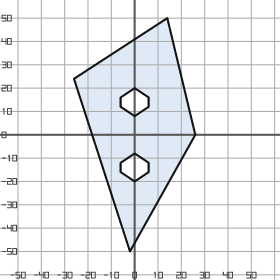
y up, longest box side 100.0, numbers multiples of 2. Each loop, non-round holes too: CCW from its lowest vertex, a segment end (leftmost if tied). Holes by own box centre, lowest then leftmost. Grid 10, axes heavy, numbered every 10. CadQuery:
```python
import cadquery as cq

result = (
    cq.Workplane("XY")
    .moveTo(-2.0, -50.0)
    .lineTo(26.0, 0.0)
    .lineTo(14.0, 50.0)
    .lineTo(-26.0, 24.0)
    .close()
    .moveTo(0.0, -20.0)
    .lineTo(6.0, -16.0)
    .lineTo(6.0, -12.0)
    .lineTo(0.0, -8.0)
    .lineTo(-6.0, -12.0)
    .lineTo(-6.0, -16.0)
    .close()
    .moveTo(0.0, 8.0)
    .lineTo(6.0, 12.0)
    .lineTo(6.0, 16.0)
    .lineTo(0.0, 20.0)
    .lineTo(-6.0, 16.0)
    .lineTo(-6.0, 12.0)
    .close()
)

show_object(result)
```